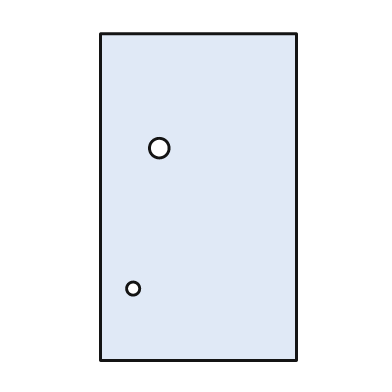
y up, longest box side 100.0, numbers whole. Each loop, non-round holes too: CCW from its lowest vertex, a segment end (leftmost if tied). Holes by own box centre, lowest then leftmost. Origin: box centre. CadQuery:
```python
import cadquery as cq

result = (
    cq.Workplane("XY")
    .moveTo(-30.0, -50.0)
    .lineTo(30.0, -50.0)
    .lineTo(30.0, 50.0)
    .lineTo(-30.0, 50.0)
    .close()
    .moveTo(-20.0, -28.0)
    .circle(2.0)
    .moveTo(-12.0, 15.0)
    .circle(3.0)
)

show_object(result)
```